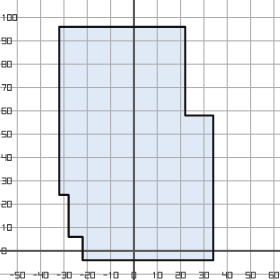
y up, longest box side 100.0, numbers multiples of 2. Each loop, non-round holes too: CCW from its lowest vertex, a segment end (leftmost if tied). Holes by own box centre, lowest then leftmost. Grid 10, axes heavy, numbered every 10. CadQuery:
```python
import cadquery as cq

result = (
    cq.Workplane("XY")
    .moveTo(-22.0, -4.0)
    .lineTo(34.0, -4.0)
    .lineTo(34.0, 58.0)
    .lineTo(22.0, 58.0)
    .lineTo(22.0, 96.0)
    .lineTo(-32.0, 96.0)
    .lineTo(-32.0, 24.0)
    .lineTo(-28.0, 24.0)
    .lineTo(-28.0, 6.0)
    .lineTo(-22.0, 6.0)
    .close()
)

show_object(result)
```